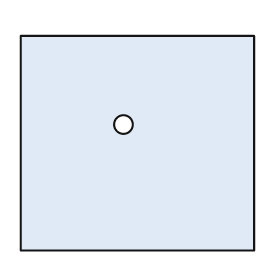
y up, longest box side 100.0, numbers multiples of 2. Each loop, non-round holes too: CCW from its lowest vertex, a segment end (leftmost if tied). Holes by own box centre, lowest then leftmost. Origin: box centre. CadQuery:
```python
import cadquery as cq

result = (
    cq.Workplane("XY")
    .moveTo(-50.0, -46.0)
    .lineTo(50.0, -46.0)
    .lineTo(50.0, 46.0)
    .lineTo(-50.0, 46.0)
    .close()
    .moveTo(-6.0, 8.0)
    .circle(4.0)
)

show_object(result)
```